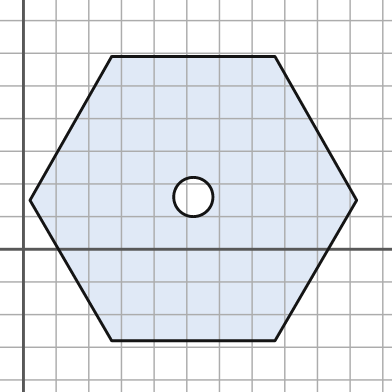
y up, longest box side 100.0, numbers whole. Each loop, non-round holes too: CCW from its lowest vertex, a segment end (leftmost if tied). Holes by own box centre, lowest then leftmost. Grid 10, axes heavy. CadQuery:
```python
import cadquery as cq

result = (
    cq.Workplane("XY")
    .moveTo(27.0, -28.0)
    .lineTo(77.0, -28.0)
    .lineTo(102.0, 15.0)
    .lineTo(77.0, 59.0)
    .lineTo(27.0, 59.0)
    .lineTo(2.0, 15.0)
    .close()
    .moveTo(52.0, 16.0)
    .circle(6.0)
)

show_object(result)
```